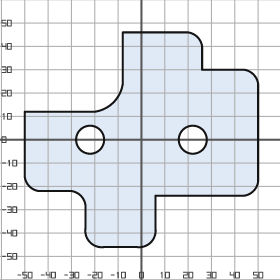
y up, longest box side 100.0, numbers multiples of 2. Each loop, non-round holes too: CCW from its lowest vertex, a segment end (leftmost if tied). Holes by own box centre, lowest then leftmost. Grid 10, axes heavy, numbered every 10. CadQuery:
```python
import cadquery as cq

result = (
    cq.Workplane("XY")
    .moveTo(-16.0, -46.0)
    .lineTo(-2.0, -46.0)
    .threePointArc((4.0, -44.0), (6.0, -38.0))
    .lineTo(6.0, -24.0)
    .lineTo(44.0, -24.0)
    .threePointArc((48.0, -22.0), (50.0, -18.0))
    .lineTo(50.0, 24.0)
    .threePointArc((48.0, 28.0), (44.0, 30.0))
    .lineTo(26.0, 30.0)
    .lineTo(26.0, 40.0)
    .threePointArc((24.0, 44.0), (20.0, 46.0))
    .lineTo(-8.0, 46.0)
    .lineTo(-8.0, 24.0)
    .threePointArc((-12.0, 16.0), (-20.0, 12.0))
    .lineTo(-50.0, 12.0)
    .lineTo(-50.0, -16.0)
    .threePointArc((-48.0, -20.0), (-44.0, -22.0))
    .lineTo(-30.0, -22.0)
    .threePointArc((-26.0, -24.0), (-24.0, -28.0))
    .lineTo(-24.0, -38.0)
    .threePointArc((-22.0, -44.0), (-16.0, -46.0))
    .close()
    .moveTo(-22.0, 0.0)
    .circle(6.0)
    .moveTo(22.0, 0.0)
    .circle(6.0)
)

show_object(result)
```